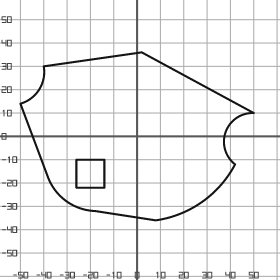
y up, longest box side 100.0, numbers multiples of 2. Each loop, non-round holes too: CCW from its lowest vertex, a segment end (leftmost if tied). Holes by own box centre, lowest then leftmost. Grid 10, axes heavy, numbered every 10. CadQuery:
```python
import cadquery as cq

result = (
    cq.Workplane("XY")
    .moveTo(8.0, -36.0)
    .threePointArc((28.0, -28.0), (42.0, -12.0))
    .threePointArc((38.0, 2.0), (50.0, 10.0))
    .lineTo(2.0, 36.0)
    .lineTo(-40.0, 30.0)
    .threePointArc((-42.0, 20.0), (-50.0, 14.0))
    .lineTo(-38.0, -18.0)
    .threePointArc((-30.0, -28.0), (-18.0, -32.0))
    .close()
    .moveTo(-26.0, -22.0)
    .lineTo(-14.0, -22.0)
    .lineTo(-14.0, -10.0)
    .lineTo(-26.0, -10.0)
    .close()
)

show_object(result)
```